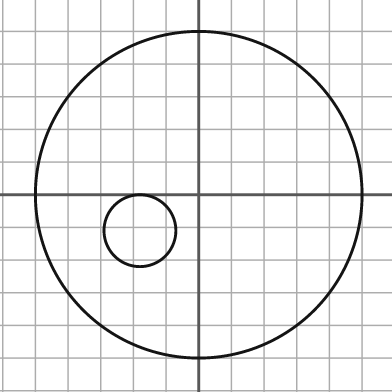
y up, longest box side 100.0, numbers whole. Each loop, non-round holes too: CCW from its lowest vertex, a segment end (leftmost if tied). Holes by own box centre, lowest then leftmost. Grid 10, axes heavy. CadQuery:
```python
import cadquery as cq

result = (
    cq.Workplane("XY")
    .moveTo(0.0, 0.0)
    .circle(50.0)
    .moveTo(-18.0, -11.0)
    .circle(11.0)
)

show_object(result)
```